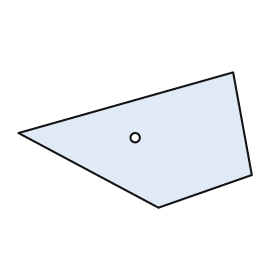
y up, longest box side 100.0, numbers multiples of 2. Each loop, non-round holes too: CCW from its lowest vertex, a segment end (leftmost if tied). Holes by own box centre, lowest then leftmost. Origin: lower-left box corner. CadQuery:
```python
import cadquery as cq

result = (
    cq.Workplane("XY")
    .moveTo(60.0, 0.0)
    .lineTo(100.0, 14.0)
    .lineTo(92.0, 58.0)
    .lineTo(0.0, 32.0)
    .close()
    .moveTo(50.0, 30.0)
    .circle(2.0)
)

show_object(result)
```